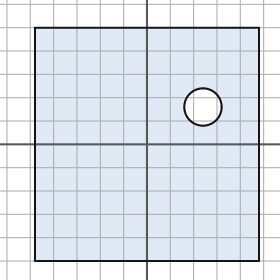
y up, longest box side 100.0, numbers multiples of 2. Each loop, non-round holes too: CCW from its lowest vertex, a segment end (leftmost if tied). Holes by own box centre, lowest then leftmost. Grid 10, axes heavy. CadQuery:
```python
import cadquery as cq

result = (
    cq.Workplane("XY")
    .moveTo(-48.0, -50.0)
    .lineTo(48.0, -50.0)
    .lineTo(48.0, 50.0)
    .lineTo(-48.0, 50.0)
    .close()
    .moveTo(24.0, 16.0)
    .circle(8.0)
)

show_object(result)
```